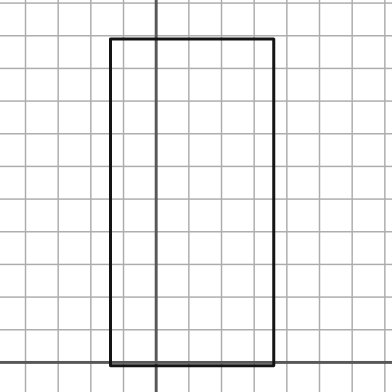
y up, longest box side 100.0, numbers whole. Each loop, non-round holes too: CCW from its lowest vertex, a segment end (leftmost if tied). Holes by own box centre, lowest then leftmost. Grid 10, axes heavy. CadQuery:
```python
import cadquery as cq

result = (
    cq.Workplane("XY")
    .moveTo(-14.0, -1.0)
    .lineTo(36.0, -1.0)
    .lineTo(36.0, 99.0)
    .lineTo(-14.0, 99.0)
    .close()
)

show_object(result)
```